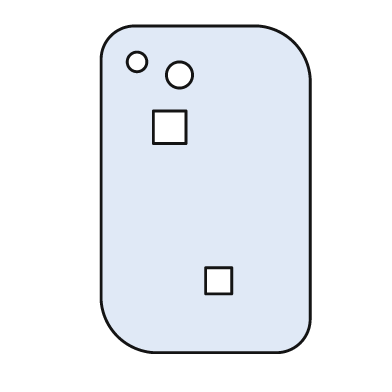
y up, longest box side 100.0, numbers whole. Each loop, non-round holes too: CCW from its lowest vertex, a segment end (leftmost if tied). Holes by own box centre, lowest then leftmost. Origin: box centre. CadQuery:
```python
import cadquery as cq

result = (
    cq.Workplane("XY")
    .moveTo(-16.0, -50.0)
    .lineTo(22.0, -50.0)
    .threePointArc((29.0, -47.0), (32.0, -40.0))
    .lineTo(32.0, 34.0)
    .threePointArc((27.0, 45.0), (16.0, 50.0))
    .lineTo(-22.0, 50.0)
    .threePointArc((-29.0, 47.0), (-32.0, 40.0))
    .lineTo(-32.0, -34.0)
    .threePointArc((-27.0, -45.0), (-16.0, -50.0))
    .close()
    .moveTo(0.0, -32.0)
    .lineTo(8.0, -32.0)
    .lineTo(8.0, -24.0)
    .lineTo(0.0, -24.0)
    .close()
    .moveTo(-16.0, 14.0)
    .lineTo(-6.0, 14.0)
    .lineTo(-6.0, 24.0)
    .lineTo(-16.0, 24.0)
    .close()
    .moveTo(-8.0, 35.0)
    .circle(4.0)
    .moveTo(-21.0, 39.0)
    .circle(3.0)
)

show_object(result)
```